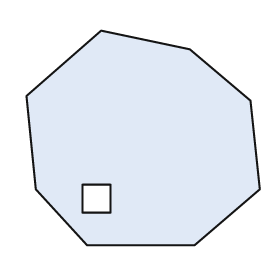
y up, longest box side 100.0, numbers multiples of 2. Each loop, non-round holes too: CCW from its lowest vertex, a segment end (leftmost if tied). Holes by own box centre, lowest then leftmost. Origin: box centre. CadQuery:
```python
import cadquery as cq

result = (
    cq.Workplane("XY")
    .moveTo(-24.0, -46.0)
    .lineTo(22.0, -46.0)
    .lineTo(50.0, -22.0)
    .lineTo(46.0, 16.0)
    .lineTo(20.0, 38.0)
    .lineTo(-18.0, 46.0)
    .lineTo(-50.0, 18.0)
    .lineTo(-46.0, -22.0)
    .close()
    .moveTo(-26.0, -32.0)
    .lineTo(-14.0, -32.0)
    .lineTo(-14.0, -20.0)
    .lineTo(-26.0, -20.0)
    .close()
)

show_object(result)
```